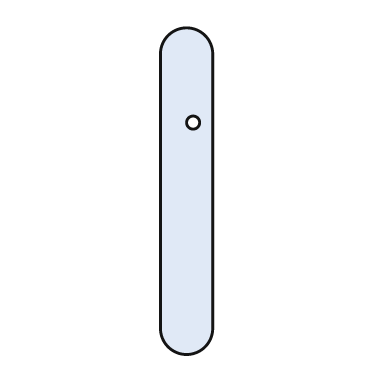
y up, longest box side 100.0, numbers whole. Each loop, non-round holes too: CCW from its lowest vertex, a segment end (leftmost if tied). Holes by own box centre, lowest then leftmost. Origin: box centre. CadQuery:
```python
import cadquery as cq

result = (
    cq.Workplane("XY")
    .moveTo(-8.0, -42.0)
    .threePointArc((0.0, -50.0), (8.0, -42.0))
    .lineTo(8.0, 42.0)
    .threePointArc((0.0, 50.0), (-8.0, 42.0))
    .close()
    .moveTo(2.0, 21.0)
    .circle(2.0)
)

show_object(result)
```